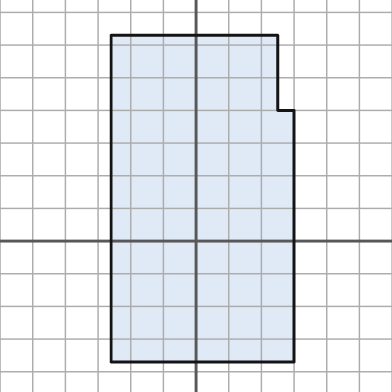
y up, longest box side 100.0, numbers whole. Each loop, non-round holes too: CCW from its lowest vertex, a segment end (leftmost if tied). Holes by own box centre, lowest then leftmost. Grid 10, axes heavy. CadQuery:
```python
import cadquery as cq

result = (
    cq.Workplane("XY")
    .moveTo(-26.0, -37.0)
    .lineTo(30.0, -37.0)
    .lineTo(30.0, 40.0)
    .lineTo(25.0, 40.0)
    .lineTo(25.0, 63.0)
    .lineTo(-26.0, 63.0)
    .close()
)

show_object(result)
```